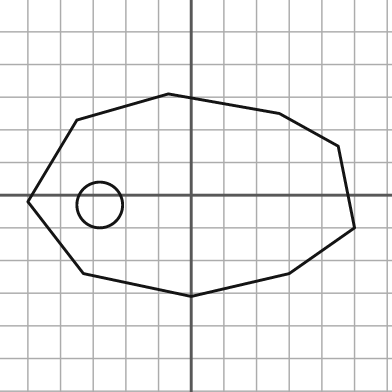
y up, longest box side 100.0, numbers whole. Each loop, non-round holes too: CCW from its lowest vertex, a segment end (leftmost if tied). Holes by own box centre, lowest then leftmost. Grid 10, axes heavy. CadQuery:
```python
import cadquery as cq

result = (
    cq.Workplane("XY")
    .moveTo(0.0, -31.0)
    .lineTo(30.0, -24.0)
    .lineTo(50.0, -10.0)
    .lineTo(45.0, 15.0)
    .lineTo(27.0, 25.0)
    .lineTo(-7.0, 31.0)
    .lineTo(-35.0, 23.0)
    .lineTo(-50.0, -2.0)
    .lineTo(-33.0, -24.0)
    .close()
    .moveTo(-28.0, -3.0)
    .circle(7.0)
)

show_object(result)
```